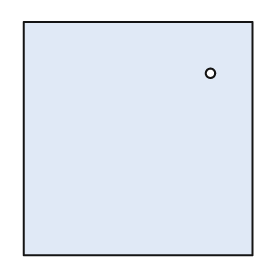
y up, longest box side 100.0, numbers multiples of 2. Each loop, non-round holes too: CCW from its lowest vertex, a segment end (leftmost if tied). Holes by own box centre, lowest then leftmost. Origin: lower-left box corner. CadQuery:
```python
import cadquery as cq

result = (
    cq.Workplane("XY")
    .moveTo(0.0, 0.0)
    .lineTo(98.0, 0.0)
    .lineTo(98.0, 100.0)
    .lineTo(0.0, 100.0)
    .close()
    .moveTo(80.0, 78.0)
    .circle(2.0)
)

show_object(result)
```